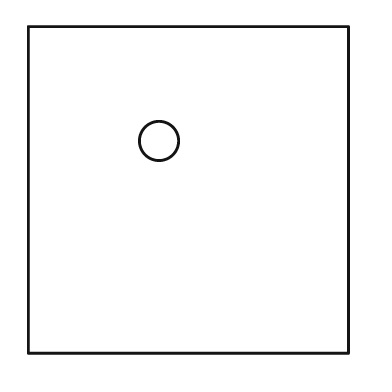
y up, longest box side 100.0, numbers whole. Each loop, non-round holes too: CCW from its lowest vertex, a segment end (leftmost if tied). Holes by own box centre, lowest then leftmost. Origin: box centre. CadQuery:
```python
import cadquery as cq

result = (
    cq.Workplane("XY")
    .moveTo(-49.0, -50.0)
    .lineTo(49.0, -50.0)
    .lineTo(49.0, 50.0)
    .lineTo(-49.0, 50.0)
    .close()
    .moveTo(-9.0, 15.0)
    .circle(6.0)
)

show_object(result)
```